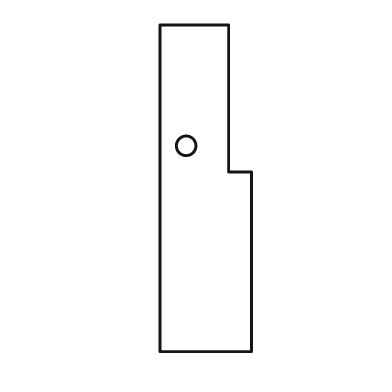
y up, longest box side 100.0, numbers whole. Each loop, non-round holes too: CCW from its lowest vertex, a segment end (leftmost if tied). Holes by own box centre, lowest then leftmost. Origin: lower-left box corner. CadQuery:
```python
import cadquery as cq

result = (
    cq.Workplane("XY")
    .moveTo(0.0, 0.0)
    .lineTo(28.0, 0.0)
    .lineTo(28.0, 55.0)
    .lineTo(21.0, 55.0)
    .lineTo(21.0, 100.0)
    .lineTo(0.0, 100.0)
    .close()
    .moveTo(8.0, 63.0)
    .circle(3.0)
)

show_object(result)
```